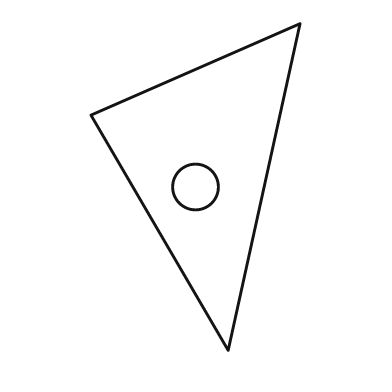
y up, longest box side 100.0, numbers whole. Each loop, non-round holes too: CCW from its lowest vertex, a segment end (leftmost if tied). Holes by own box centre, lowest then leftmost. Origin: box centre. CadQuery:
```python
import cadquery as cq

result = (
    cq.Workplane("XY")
    .moveTo(10.0, -50.0)
    .lineTo(32.0, 50.0)
    .lineTo(-32.0, 22.0)
    .close()
    .moveTo(0.0, 0.0)
    .circle(7.0)
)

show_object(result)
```